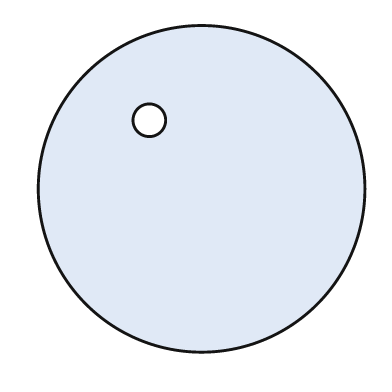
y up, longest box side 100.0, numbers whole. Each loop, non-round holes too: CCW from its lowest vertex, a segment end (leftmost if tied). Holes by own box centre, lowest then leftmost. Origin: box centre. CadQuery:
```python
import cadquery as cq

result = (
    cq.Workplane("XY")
    .moveTo(0.0, 0.0)
    .circle(50.0)
    .moveTo(-16.0, 21.0)
    .circle(5.0)
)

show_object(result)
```